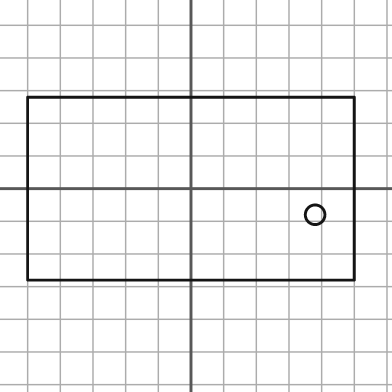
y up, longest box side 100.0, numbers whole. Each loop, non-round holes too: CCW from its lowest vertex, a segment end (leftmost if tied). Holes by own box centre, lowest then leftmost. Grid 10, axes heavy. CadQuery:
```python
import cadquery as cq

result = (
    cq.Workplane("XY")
    .moveTo(-50.0, -28.0)
    .lineTo(50.0, -28.0)
    .lineTo(50.0, 28.0)
    .lineTo(-50.0, 28.0)
    .close()
    .moveTo(38.0, -8.0)
    .circle(3.0)
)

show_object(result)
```